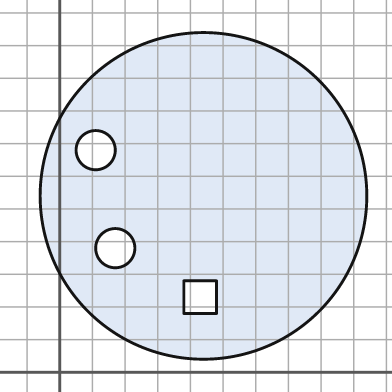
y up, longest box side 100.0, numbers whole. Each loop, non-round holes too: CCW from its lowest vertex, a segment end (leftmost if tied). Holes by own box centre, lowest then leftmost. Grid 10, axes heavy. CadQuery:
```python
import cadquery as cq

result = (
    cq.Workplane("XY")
    .moveTo(44.0, 54.0)
    .circle(50.0)
    .moveTo(38.0, 18.0)
    .lineTo(48.0, 18.0)
    .lineTo(48.0, 28.0)
    .lineTo(38.0, 28.0)
    .close()
    .moveTo(17.0, 38.0)
    .circle(6.0)
    .moveTo(11.0, 68.0)
    .circle(6.0)
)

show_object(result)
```